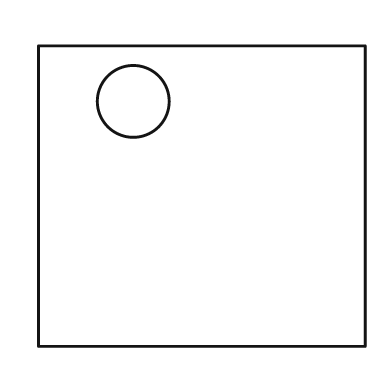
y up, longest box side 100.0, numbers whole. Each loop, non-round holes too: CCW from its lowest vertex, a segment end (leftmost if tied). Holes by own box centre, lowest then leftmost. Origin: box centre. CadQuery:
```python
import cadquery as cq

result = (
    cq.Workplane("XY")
    .moveTo(-50.0, -46.0)
    .lineTo(50.0, -46.0)
    .lineTo(50.0, 46.0)
    .lineTo(-50.0, 46.0)
    .close()
    .moveTo(-21.0, 29.0)
    .circle(11.0)
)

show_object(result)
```